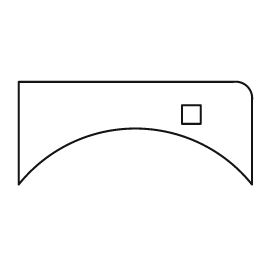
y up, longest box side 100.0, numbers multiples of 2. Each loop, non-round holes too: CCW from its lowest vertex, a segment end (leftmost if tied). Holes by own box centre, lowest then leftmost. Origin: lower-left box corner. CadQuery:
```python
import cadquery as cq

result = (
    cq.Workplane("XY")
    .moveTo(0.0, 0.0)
    .threePointArc((50.0, 24.0), (100.0, 0.0))
    .lineTo(100.0, 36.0)
    .threePointArc((98.0, 42.0), (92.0, 44.0))
    .lineTo(0.0, 44.0)
    .close()
    .moveTo(70.0, 26.0)
    .lineTo(78.0, 26.0)
    .lineTo(78.0, 34.0)
    .lineTo(70.0, 34.0)
    .close()
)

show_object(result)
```